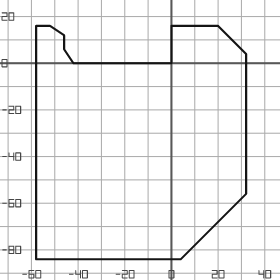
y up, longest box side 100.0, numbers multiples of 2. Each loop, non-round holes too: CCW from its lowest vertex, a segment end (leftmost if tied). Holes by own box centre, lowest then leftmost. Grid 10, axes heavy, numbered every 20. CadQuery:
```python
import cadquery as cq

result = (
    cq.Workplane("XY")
    .moveTo(-58.0, -84.0)
    .lineTo(4.0, -84.0)
    .lineTo(32.0, -56.0)
    .lineTo(32.0, 4.0)
    .lineTo(20.0, 16.0)
    .lineTo(0.0, 16.0)
    .lineTo(0.0, 0.0)
    .lineTo(-42.0, 0.0)
    .lineTo(-46.0, 6.0)
    .lineTo(-46.0, 12.0)
    .lineTo(-52.0, 16.0)
    .lineTo(-58.0, 16.0)
    .close()
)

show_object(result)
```